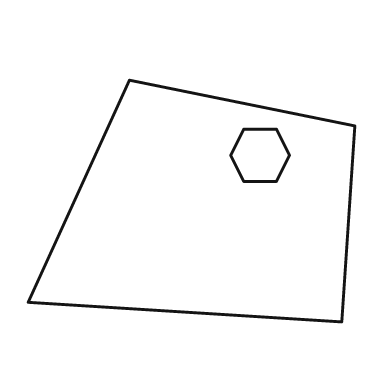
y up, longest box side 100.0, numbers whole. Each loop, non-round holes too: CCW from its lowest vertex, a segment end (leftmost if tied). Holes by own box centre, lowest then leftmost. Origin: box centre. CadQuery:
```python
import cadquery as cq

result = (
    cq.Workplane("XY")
    .moveTo(46.0, -37.0)
    .lineTo(50.0, 23.0)
    .lineTo(-19.0, 37.0)
    .lineTo(-50.0, -31.0)
    .close()
    .moveTo(16.0, 6.0)
    .lineTo(26.0, 6.0)
    .lineTo(30.0, 14.0)
    .lineTo(26.0, 22.0)
    .lineTo(16.0, 22.0)
    .lineTo(12.0, 14.0)
    .close()
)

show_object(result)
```